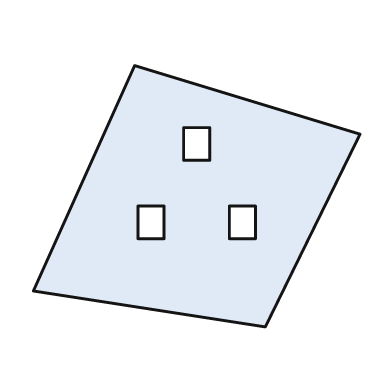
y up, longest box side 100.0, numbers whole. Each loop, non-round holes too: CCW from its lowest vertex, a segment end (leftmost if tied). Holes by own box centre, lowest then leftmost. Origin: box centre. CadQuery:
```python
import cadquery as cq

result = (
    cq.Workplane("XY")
    .moveTo(21.0, -40.0)
    .lineTo(50.0, 19.0)
    .lineTo(-19.0, 40.0)
    .lineTo(-50.0, -29.0)
    .close()
    .moveTo(-18.0, -13.0)
    .lineTo(-10.0, -13.0)
    .lineTo(-10.0, -3.0)
    .lineTo(-18.0, -3.0)
    .close()
    .moveTo(10.0, -13.0)
    .lineTo(18.0, -13.0)
    .lineTo(18.0, -3.0)
    .lineTo(10.0, -3.0)
    .close()
    .moveTo(-4.0, 11.0)
    .lineTo(4.0, 11.0)
    .lineTo(4.0, 21.0)
    .lineTo(-4.0, 21.0)
    .close()
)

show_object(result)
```